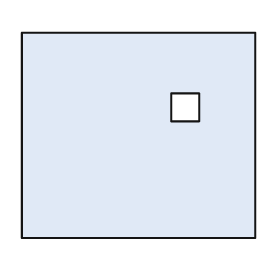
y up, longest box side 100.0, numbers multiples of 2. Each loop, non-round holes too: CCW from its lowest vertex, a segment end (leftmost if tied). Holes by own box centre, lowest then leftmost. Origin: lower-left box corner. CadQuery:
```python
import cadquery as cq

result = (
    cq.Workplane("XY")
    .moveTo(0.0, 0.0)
    .lineTo(100.0, 0.0)
    .lineTo(100.0, 88.0)
    .lineTo(0.0, 88.0)
    .close()
    .moveTo(64.0, 50.0)
    .lineTo(76.0, 50.0)
    .lineTo(76.0, 62.0)
    .lineTo(64.0, 62.0)
    .close()
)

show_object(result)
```